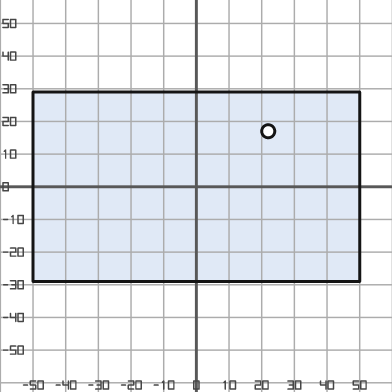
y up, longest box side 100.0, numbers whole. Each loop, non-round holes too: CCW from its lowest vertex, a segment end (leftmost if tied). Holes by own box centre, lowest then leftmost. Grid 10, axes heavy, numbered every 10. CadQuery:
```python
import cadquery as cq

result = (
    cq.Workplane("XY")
    .moveTo(-50.0, -29.0)
    .lineTo(50.0, -29.0)
    .lineTo(50.0, 29.0)
    .lineTo(-50.0, 29.0)
    .close()
    .moveTo(22.0, 17.0)
    .circle(2.0)
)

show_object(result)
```